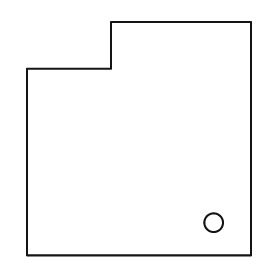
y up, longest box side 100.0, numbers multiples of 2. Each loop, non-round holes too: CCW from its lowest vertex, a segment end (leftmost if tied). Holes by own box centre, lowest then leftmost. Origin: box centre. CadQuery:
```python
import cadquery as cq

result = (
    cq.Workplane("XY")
    .moveTo(-48.0, -50.0)
    .lineTo(48.0, -50.0)
    .lineTo(48.0, 50.0)
    .lineTo(-12.0, 50.0)
    .lineTo(-12.0, 30.0)
    .lineTo(-48.0, 30.0)
    .close()
    .moveTo(32.0, -36.0)
    .circle(4.0)
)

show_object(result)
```